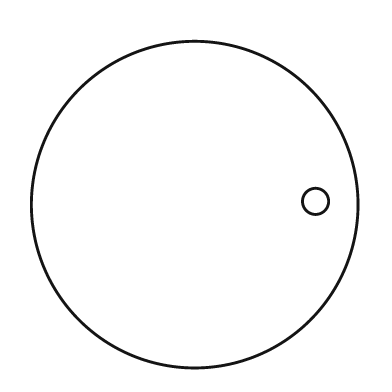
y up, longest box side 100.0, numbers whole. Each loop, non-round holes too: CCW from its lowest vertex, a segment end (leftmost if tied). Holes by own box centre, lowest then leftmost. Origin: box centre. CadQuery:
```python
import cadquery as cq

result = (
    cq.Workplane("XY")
    .moveTo(0.0, 0.0)
    .circle(50.0)
    .moveTo(37.0, 1.0)
    .circle(4.0)
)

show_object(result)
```